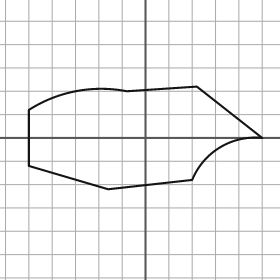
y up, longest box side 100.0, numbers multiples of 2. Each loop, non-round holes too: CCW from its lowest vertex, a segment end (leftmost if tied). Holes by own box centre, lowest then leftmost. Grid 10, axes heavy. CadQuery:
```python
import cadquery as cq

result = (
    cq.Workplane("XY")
    .moveTo(-16.0, -22.0)
    .lineTo(20.0, -18.0)
    .threePointArc((32.0, -4.0), (50.0, 0.0))
    .lineTo(22.0, 22.0)
    .lineTo(-8.0, 20.0)
    .threePointArc((-30.0, 20.0), (-50.0, 12.0))
    .lineTo(-50.0, -12.0)
    .close()
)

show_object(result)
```